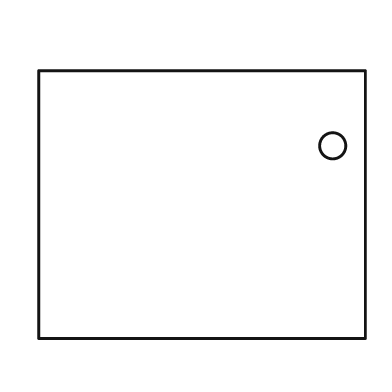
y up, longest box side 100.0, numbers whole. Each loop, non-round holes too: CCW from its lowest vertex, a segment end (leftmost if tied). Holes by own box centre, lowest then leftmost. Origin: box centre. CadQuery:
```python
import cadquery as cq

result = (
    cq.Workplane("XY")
    .moveTo(-50.0, -41.0)
    .lineTo(50.0, -41.0)
    .lineTo(50.0, 41.0)
    .lineTo(-50.0, 41.0)
    .close()
    .moveTo(40.0, 18.0)
    .circle(4.0)
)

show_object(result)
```